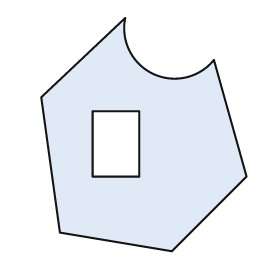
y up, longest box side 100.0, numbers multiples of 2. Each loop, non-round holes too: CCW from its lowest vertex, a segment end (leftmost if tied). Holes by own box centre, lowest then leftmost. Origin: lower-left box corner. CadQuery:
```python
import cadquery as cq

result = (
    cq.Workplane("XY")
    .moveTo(56.0, 0.0)
    .lineTo(88.0, 32.0)
    .lineTo(74.0, 82.0)
    .threePointArc((48.0, 76.0), (36.0, 100.0))
    .lineTo(0.0, 66.0)
    .lineTo(8.0, 8.0)
    .close()
    .moveTo(22.0, 32.0)
    .lineTo(42.0, 32.0)
    .lineTo(42.0, 60.0)
    .lineTo(22.0, 60.0)
    .close()
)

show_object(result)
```